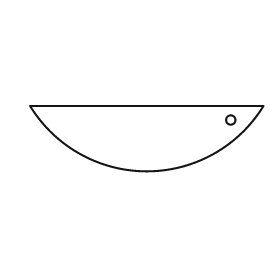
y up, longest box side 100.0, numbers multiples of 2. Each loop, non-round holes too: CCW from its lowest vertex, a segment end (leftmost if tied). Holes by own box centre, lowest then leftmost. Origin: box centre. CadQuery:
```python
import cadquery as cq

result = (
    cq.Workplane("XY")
    .moveTo(-50.0, 14.0)
    .threePointArc((0.0, -14.0), (50.0, 14.0))
    .close()
    .moveTo(36.0, 8.0)
    .circle(2.0)
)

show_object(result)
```